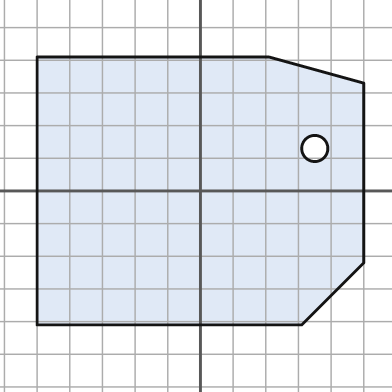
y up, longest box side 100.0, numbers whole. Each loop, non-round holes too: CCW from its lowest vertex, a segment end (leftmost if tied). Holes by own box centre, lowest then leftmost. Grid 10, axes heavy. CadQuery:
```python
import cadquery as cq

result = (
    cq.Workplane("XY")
    .moveTo(-50.0, -41.0)
    .lineTo(31.0, -41.0)
    .lineTo(50.0, -22.0)
    .lineTo(50.0, 33.0)
    .lineTo(21.0, 41.0)
    .lineTo(-50.0, 41.0)
    .close()
    .moveTo(35.0, 13.0)
    .circle(4.0)
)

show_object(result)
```